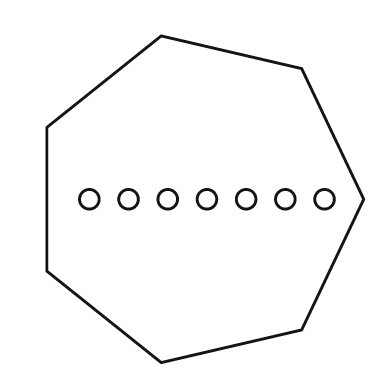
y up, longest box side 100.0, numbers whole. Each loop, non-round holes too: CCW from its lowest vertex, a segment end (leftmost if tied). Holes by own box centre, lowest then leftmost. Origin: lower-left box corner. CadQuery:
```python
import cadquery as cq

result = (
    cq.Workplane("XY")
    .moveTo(35.0, 0.0)
    .lineTo(78.0, 10.0)
    .lineTo(97.0, 50.0)
    .lineTo(78.0, 90.0)
    .lineTo(35.0, 100.0)
    .lineTo(0.0, 72.0)
    .lineTo(0.0, 28.0)
    .close()
    .moveTo(13.0, 50.0)
    .circle(3.0)
    .moveTo(25.0, 50.0)
    .circle(3.0)
    .moveTo(37.0, 50.0)
    .circle(3.0)
    .moveTo(49.0, 50.0)
    .circle(3.0)
    .moveTo(61.0, 50.0)
    .circle(3.0)
    .moveTo(73.0, 50.0)
    .circle(3.0)
    .moveTo(85.0, 50.0)
    .circle(3.0)
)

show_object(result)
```